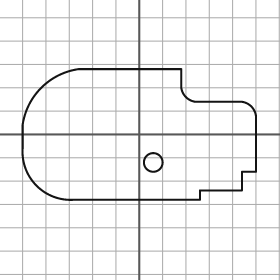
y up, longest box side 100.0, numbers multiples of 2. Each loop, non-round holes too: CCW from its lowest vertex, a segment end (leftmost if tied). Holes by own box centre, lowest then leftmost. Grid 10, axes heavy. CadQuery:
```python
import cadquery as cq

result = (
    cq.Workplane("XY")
    .moveTo(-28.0, -28.0)
    .lineTo(26.0, -28.0)
    .lineTo(26.0, -24.0)
    .lineTo(44.0, -24.0)
    .lineTo(44.0, -16.0)
    .lineTo(50.0, -16.0)
    .lineTo(50.0, 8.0)
    .threePointArc((48.0, 12.0), (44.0, 14.0))
    .lineTo(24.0, 14.0)
    .threePointArc((20.0, 16.0), (18.0, 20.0))
    .lineTo(18.0, 28.0)
    .lineTo(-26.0, 28.0)
    .threePointArc((-42.0, 20.0), (-50.0, 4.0))
    .lineTo(-50.0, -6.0)
    .threePointArc((-44.0, -22.0), (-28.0, -28.0))
    .close()
    .moveTo(6.0, -12.0)
    .circle(4.0)
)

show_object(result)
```